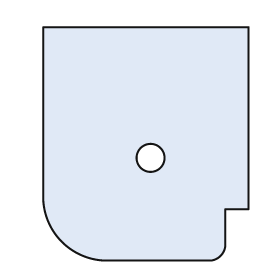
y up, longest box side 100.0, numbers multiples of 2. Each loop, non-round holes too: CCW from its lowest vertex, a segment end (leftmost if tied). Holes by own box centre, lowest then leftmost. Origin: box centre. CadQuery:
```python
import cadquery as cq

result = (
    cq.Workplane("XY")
    .moveTo(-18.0, -50.0)
    .lineTo(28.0, -50.0)
    .threePointArc((32.0, -48.0), (34.0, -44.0))
    .lineTo(34.0, -28.0)
    .lineTo(44.0, -28.0)
    .lineTo(44.0, 50.0)
    .lineTo(-44.0, 50.0)
    .lineTo(-44.0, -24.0)
    .threePointArc((-36.0, -42.0), (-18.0, -50.0))
    .close()
    .moveTo(2.0, -6.0)
    .circle(6.0)
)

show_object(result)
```